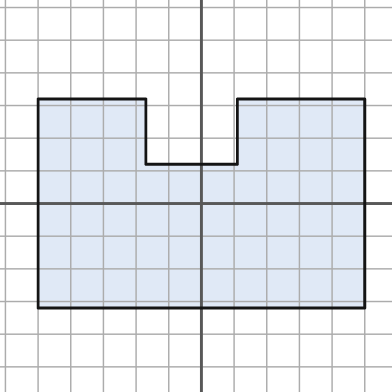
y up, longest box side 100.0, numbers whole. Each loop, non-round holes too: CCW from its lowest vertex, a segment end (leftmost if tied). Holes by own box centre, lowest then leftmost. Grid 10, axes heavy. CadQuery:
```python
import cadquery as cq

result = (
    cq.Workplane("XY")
    .moveTo(-50.0, -32.0)
    .lineTo(50.0, -32.0)
    .lineTo(50.0, 32.0)
    .lineTo(11.0, 32.0)
    .lineTo(11.0, 12.0)
    .lineTo(-17.0, 12.0)
    .lineTo(-17.0, 32.0)
    .lineTo(-50.0, 32.0)
    .close()
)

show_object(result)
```